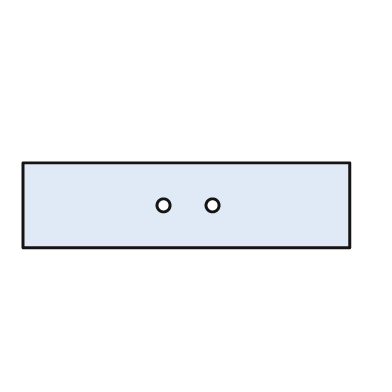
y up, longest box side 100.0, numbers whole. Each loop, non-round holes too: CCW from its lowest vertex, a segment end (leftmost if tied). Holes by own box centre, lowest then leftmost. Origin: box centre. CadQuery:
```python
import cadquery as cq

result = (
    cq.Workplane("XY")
    .moveTo(-50.0, -13.0)
    .lineTo(50.0, -13.0)
    .lineTo(50.0, 13.0)
    .lineTo(-50.0, 13.0)
    .close()
    .moveTo(-7.0, 0.0)
    .circle(2.0)
    .moveTo(8.0, 0.0)
    .circle(2.0)
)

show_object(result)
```